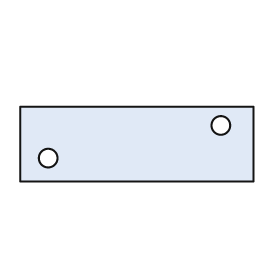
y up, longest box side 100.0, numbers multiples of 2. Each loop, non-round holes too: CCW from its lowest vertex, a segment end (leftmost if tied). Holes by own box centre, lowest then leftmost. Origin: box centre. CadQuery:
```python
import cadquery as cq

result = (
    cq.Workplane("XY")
    .moveTo(-50.0, -16.0)
    .lineTo(50.0, -16.0)
    .lineTo(50.0, 16.0)
    .lineTo(-50.0, 16.0)
    .close()
    .moveTo(-38.0, -6.0)
    .circle(4.0)
    .moveTo(36.0, 8.0)
    .circle(4.0)
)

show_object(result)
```